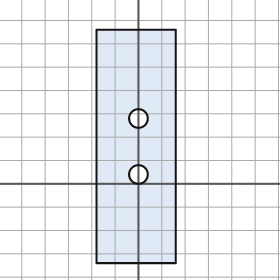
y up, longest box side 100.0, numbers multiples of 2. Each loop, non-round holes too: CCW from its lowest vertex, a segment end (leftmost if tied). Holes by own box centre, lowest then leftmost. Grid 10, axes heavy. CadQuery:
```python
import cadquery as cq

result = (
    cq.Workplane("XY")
    .moveTo(-18.0, -34.0)
    .lineTo(16.0, -34.0)
    .lineTo(16.0, 66.0)
    .lineTo(-18.0, 66.0)
    .close()
    .moveTo(0.0, 4.0)
    .circle(4.0)
    .moveTo(0.0, 28.0)
    .circle(4.0)
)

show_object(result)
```